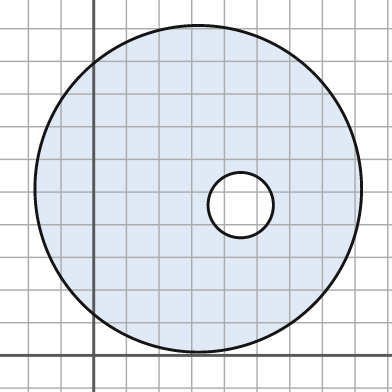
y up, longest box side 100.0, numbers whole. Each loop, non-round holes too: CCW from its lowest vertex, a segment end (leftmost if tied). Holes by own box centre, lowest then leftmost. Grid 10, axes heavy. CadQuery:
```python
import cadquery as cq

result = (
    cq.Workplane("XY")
    .moveTo(32.0, 51.0)
    .circle(50.0)
    .moveTo(45.0, 46.0)
    .circle(10.0)
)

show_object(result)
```